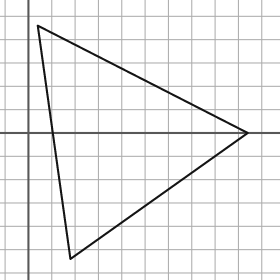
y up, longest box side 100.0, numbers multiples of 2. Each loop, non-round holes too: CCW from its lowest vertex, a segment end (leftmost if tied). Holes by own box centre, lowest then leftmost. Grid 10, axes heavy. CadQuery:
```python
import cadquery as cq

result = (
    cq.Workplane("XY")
    .moveTo(18.0, -54.0)
    .lineTo(94.0, 0.0)
    .lineTo(4.0, 46.0)
    .close()
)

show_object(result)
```